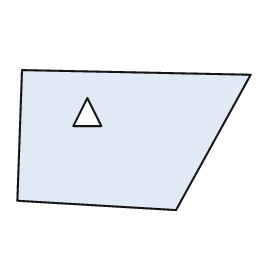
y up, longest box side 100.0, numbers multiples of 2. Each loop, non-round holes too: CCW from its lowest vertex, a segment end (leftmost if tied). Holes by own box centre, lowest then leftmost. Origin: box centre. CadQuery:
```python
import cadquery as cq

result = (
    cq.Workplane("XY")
    .moveTo(18.0, -30.0)
    .lineTo(50.0, 28.0)
    .lineTo(-48.0, 30.0)
    .lineTo(-50.0, -26.0)
    .close()
    .moveTo(-26.0, 6.0)
    .lineTo(-14.0, 6.0)
    .lineTo(-20.0, 18.0)
    .close()
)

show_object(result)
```